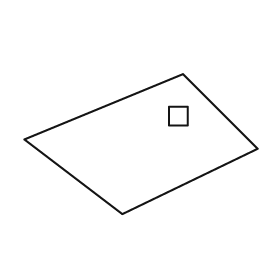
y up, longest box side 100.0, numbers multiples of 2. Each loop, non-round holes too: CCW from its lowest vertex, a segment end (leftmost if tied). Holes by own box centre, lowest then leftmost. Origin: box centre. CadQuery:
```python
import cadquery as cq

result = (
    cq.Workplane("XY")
    .moveTo(-8.0, -30.0)
    .lineTo(50.0, -2.0)
    .lineTo(18.0, 30.0)
    .lineTo(-50.0, 2.0)
    .close()
    .moveTo(12.0, 8.0)
    .lineTo(20.0, 8.0)
    .lineTo(20.0, 16.0)
    .lineTo(12.0, 16.0)
    .close()
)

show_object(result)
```